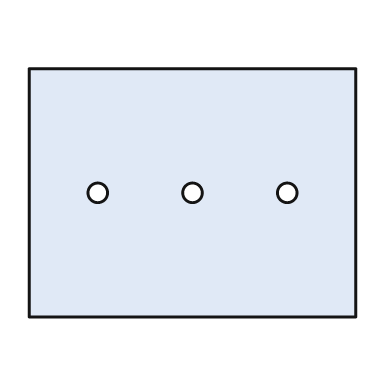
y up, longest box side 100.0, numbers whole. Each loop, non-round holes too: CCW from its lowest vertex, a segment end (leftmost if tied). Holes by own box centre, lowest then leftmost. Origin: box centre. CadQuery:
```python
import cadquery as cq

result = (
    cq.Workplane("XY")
    .moveTo(-50.0, -38.0)
    .lineTo(50.0, -38.0)
    .lineTo(50.0, 38.0)
    .lineTo(-50.0, 38.0)
    .close()
    .moveTo(-29.0, 0.0)
    .circle(3.0)
    .moveTo(0.0, 0.0)
    .circle(3.0)
    .moveTo(29.0, 0.0)
    .circle(3.0)
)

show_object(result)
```